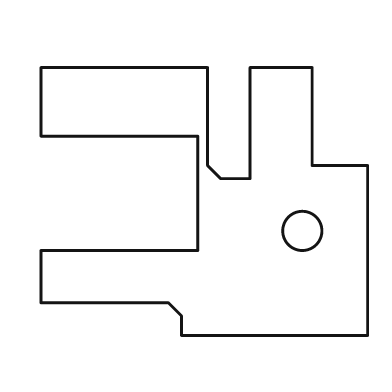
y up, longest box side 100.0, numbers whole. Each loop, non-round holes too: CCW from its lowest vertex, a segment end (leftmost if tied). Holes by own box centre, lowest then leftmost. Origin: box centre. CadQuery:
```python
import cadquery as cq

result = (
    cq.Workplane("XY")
    .moveTo(-7.0, -41.0)
    .lineTo(50.0, -41.0)
    .lineTo(50.0, 11.0)
    .lineTo(33.0, 11.0)
    .lineTo(33.0, 41.0)
    .lineTo(14.0, 41.0)
    .lineTo(14.0, 7.0)
    .lineTo(5.0, 7.0)
    .lineTo(1.0, 11.0)
    .lineTo(1.0, 41.0)
    .lineTo(-50.0, 41.0)
    .lineTo(-50.0, 20.0)
    .lineTo(-2.0, 20.0)
    .lineTo(-2.0, -15.0)
    .lineTo(-50.0, -15.0)
    .lineTo(-50.0, -31.0)
    .lineTo(-11.0, -31.0)
    .lineTo(-7.0, -35.0)
    .close()
    .moveTo(30.0, -9.0)
    .circle(6.0)
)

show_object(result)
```